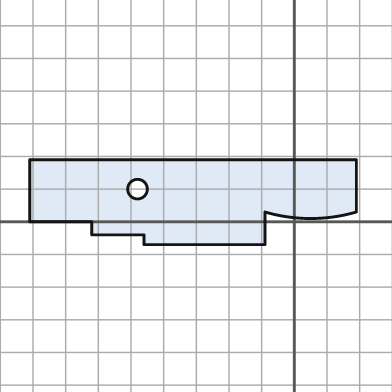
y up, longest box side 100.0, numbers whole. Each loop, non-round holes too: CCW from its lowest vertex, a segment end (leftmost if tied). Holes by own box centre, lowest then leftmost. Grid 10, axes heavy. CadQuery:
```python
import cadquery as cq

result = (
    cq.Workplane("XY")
    .moveTo(-46.0, -7.0)
    .lineTo(-9.0, -7.0)
    .lineTo(-9.0, 3.0)
    .threePointArc((5.0, 1.0), (19.0, 3.0))
    .lineTo(19.0, 19.0)
    .lineTo(-81.0, 19.0)
    .lineTo(-81.0, 0.0)
    .lineTo(-62.0, 0.0)
    .lineTo(-62.0, -4.0)
    .lineTo(-46.0, -4.0)
    .close()
    .moveTo(-48.0, 10.0)
    .circle(3.0)
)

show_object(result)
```